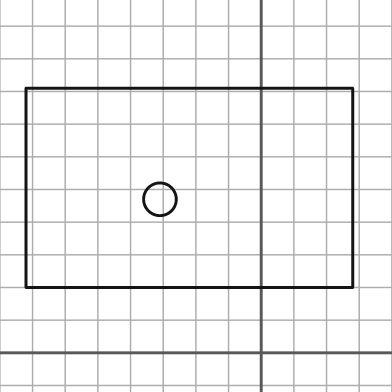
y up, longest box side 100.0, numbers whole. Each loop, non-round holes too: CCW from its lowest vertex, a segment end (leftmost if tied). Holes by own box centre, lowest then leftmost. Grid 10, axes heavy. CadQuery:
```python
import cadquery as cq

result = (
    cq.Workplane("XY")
    .moveTo(-72.0, 20.0)
    .lineTo(28.0, 20.0)
    .lineTo(28.0, 81.0)
    .lineTo(-72.0, 81.0)
    .close()
    .moveTo(-31.0, 47.0)
    .circle(5.0)
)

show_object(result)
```